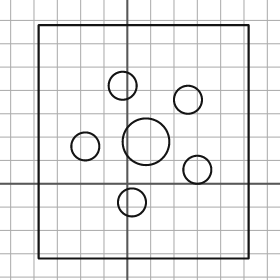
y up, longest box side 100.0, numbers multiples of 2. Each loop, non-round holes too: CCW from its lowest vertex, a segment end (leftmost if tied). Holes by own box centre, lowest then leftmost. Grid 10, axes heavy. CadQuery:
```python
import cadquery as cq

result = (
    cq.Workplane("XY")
    .moveTo(-38.0, -32.0)
    .lineTo(52.0, -32.0)
    .lineTo(52.0, 68.0)
    .lineTo(-38.0, 68.0)
    .close()
    .moveTo(2.0, -8.0)
    .circle(6.0)
    .moveTo(30.0, 6.0)
    .circle(6.0)
    .moveTo(-18.0, 16.0)
    .circle(6.0)
    .moveTo(8.0, 18.0)
    .circle(10.0)
    .moveTo(26.0, 36.0)
    .circle(6.0)
    .moveTo(-2.0, 42.0)
    .circle(6.0)
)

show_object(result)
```